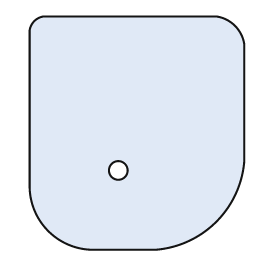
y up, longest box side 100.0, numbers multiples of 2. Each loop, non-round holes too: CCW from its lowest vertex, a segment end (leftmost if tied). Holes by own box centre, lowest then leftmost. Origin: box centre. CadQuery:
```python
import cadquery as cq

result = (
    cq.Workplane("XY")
    .moveTo(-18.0, -50.0)
    .lineTo(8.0, -50.0)
    .threePointArc((34.0, -38.0), (46.0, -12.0))
    .lineTo(46.0, 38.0)
    .threePointArc((42.0, 46.0), (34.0, 50.0))
    .lineTo(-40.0, 50.0)
    .threePointArc((-44.0, 48.0), (-46.0, 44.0))
    .lineTo(-46.0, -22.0)
    .threePointArc((-38.0, -42.0), (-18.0, -50.0))
    .close()
    .moveTo(-8.0, -16.0)
    .circle(4.0)
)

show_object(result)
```